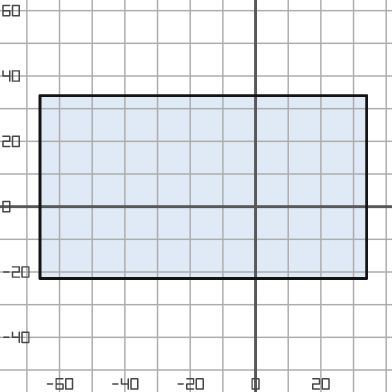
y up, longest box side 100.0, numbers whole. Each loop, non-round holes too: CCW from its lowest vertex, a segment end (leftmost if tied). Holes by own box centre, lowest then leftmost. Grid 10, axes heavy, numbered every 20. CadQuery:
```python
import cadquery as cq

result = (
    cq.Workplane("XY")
    .moveTo(-66.0, -22.0)
    .lineTo(34.0, -22.0)
    .lineTo(34.0, 34.0)
    .lineTo(-66.0, 34.0)
    .close()
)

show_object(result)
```